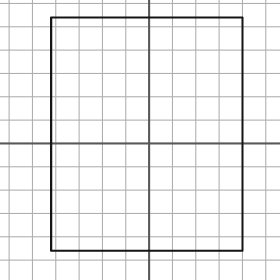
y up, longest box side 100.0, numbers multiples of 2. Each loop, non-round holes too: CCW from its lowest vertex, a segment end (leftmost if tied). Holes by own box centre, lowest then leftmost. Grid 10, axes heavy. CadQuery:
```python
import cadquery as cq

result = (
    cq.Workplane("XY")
    .moveTo(-42.0, -46.0)
    .lineTo(40.0, -46.0)
    .lineTo(40.0, 54.0)
    .lineTo(-42.0, 54.0)
    .close()
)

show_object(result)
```